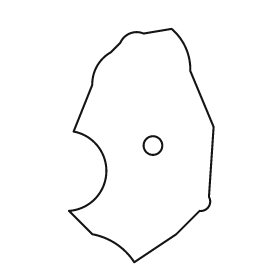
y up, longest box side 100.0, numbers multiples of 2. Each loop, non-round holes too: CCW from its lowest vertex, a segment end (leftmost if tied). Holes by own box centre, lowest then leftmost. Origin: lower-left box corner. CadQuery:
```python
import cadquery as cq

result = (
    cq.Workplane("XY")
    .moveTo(28.0, 0.0)
    .lineTo(46.0, 12.0)
    .lineTo(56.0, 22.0)
    .threePointArc((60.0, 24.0), (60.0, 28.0))
    .lineTo(62.0, 58.0)
    .lineTo(52.0, 82.0)
    .threePointArc((50.0, 92.0), (44.0, 100.0))
    .lineTo(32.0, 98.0)
    .threePointArc((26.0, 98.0), (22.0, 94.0))
    .lineTo(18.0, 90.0)
    .threePointArc((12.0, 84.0), (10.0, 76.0))
    .lineTo(2.0, 56.0)
    .threePointArc((16.0, 38.0), (0.0, 22.0))
    .lineTo(10.0, 12.0)
    .threePointArc((20.0, 8.0), (28.0, 0.0))
    .close()
    .moveTo(36.0, 50.0)
    .circle(4.0)
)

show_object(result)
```